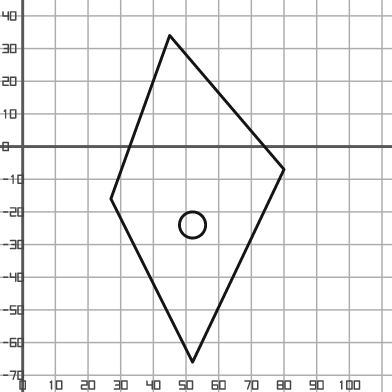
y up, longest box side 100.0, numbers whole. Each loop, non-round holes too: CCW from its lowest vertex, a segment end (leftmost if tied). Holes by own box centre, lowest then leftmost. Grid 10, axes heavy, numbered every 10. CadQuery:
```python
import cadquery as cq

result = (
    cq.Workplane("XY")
    .moveTo(52.0, -66.0)
    .lineTo(80.0, -7.0)
    .lineTo(45.0, 34.0)
    .lineTo(27.0, -16.0)
    .close()
    .moveTo(52.0, -24.0)
    .circle(4.0)
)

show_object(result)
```